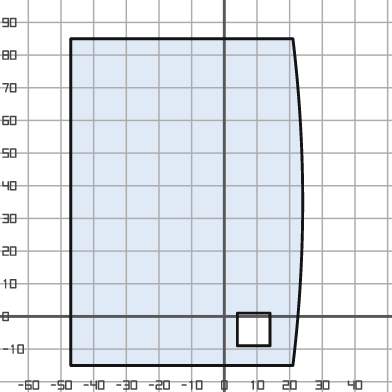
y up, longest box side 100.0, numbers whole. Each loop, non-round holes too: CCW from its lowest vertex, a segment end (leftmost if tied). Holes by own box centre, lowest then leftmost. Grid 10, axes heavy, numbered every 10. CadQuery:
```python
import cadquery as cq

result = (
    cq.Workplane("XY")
    .moveTo(-47.0, -15.0)
    .lineTo(21.0, -15.0)
    .threePointArc((24.0, 35.0), (21.0, 85.0))
    .lineTo(-47.0, 85.0)
    .close()
    .moveTo(4.0, -9.0)
    .lineTo(14.0, -9.0)
    .lineTo(14.0, 1.0)
    .lineTo(4.0, 1.0)
    .close()
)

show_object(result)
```